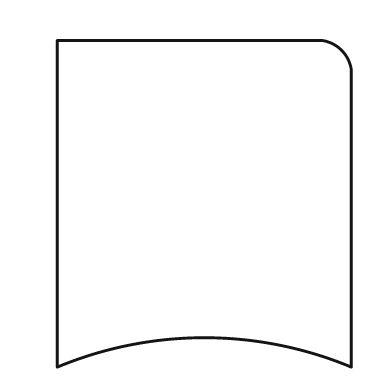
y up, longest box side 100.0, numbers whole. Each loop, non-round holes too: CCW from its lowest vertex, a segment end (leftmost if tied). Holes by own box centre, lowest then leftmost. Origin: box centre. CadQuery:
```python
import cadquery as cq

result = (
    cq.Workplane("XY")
    .moveTo(-45.0, -50.0)
    .threePointArc((0.0, -41.0), (45.0, -50.0))
    .lineTo(45.0, 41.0)
    .threePointArc((42.0, 47.0), (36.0, 50.0))
    .lineTo(-45.0, 50.0)
    .close()
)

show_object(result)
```